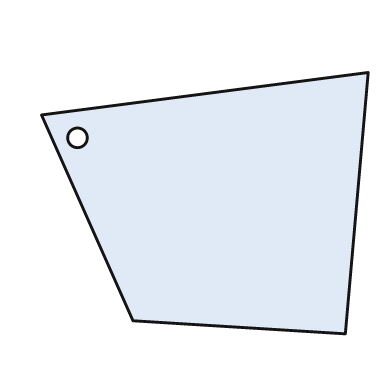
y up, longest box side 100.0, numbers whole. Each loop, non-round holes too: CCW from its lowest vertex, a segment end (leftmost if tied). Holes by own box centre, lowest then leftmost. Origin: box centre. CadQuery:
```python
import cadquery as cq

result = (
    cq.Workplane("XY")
    .moveTo(43.0, -40.0)
    .lineTo(50.0, 40.0)
    .lineTo(-50.0, 27.0)
    .lineTo(-22.0, -36.0)
    .close()
    .moveTo(-39.0, 20.0)
    .circle(3.0)
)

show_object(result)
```